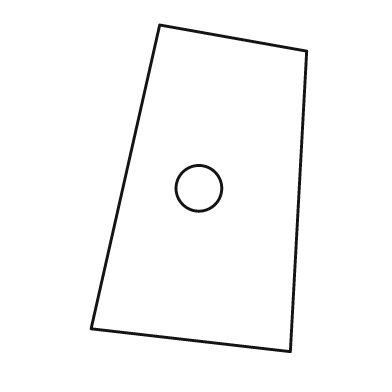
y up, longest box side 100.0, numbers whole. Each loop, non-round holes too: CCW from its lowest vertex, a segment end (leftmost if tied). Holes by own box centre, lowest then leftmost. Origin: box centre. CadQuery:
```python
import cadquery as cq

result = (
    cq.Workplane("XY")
    .moveTo(28.0, -50.0)
    .lineTo(33.0, 42.0)
    .lineTo(-12.0, 50.0)
    .lineTo(-33.0, -43.0)
    .close()
    .moveTo(0.0, 0.0)
    .circle(7.0)
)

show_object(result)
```